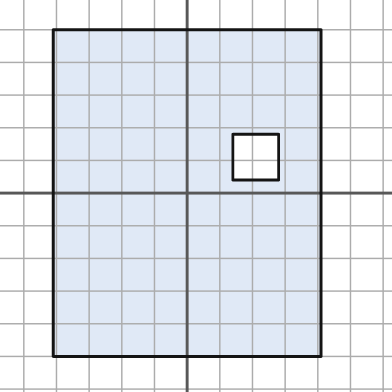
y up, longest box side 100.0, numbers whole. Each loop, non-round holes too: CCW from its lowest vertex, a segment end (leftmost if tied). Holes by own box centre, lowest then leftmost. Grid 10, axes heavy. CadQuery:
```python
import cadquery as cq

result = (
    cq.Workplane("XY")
    .moveTo(-41.0, -50.0)
    .lineTo(41.0, -50.0)
    .lineTo(41.0, 50.0)
    .lineTo(-41.0, 50.0)
    .close()
    .moveTo(14.0, 4.0)
    .lineTo(28.0, 4.0)
    .lineTo(28.0, 18.0)
    .lineTo(14.0, 18.0)
    .close()
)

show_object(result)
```